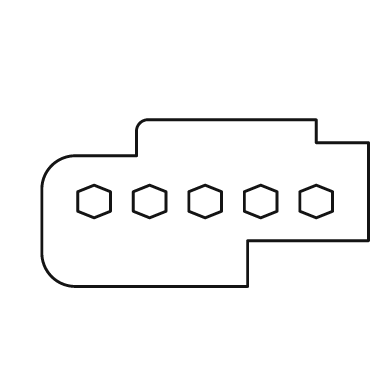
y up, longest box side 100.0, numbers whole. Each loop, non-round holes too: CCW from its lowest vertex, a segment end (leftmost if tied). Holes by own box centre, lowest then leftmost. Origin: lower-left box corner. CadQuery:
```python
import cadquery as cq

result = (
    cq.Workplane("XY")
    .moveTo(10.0, 0.0)
    .lineTo(63.0, 0.0)
    .lineTo(63.0, 14.0)
    .lineTo(100.0, 14.0)
    .lineTo(100.0, 44.0)
    .lineTo(84.0, 44.0)
    .lineTo(84.0, 51.0)
    .lineTo(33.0, 51.0)
    .threePointArc((30.0, 50.0), (29.0, 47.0))
    .lineTo(29.0, 40.0)
    .lineTo(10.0, 40.0)
    .threePointArc((3.0, 37.0), (0.0, 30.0))
    .lineTo(0.0, 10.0)
    .threePointArc((3.0, 3.0), (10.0, 0.0))
    .close()
    .moveTo(16.0, 21.0)
    .lineTo(21.0, 23.0)
    .lineTo(21.0, 29.0)
    .lineTo(16.0, 31.0)
    .lineTo(11.0, 29.0)
    .lineTo(11.0, 23.0)
    .close()
    .moveTo(33.0, 21.0)
    .lineTo(38.0, 23.0)
    .lineTo(38.0, 29.0)
    .lineTo(33.0, 31.0)
    .lineTo(28.0, 29.0)
    .lineTo(28.0, 23.0)
    .close()
    .moveTo(50.0, 21.0)
    .lineTo(55.0, 23.0)
    .lineTo(55.0, 29.0)
    .lineTo(50.0, 31.0)
    .lineTo(45.0, 29.0)
    .lineTo(45.0, 23.0)
    .close()
    .moveTo(67.0, 21.0)
    .lineTo(72.0, 23.0)
    .lineTo(72.0, 29.0)
    .lineTo(67.0, 31.0)
    .lineTo(62.0, 29.0)
    .lineTo(62.0, 23.0)
    .close()
    .moveTo(84.0, 21.0)
    .lineTo(89.0, 23.0)
    .lineTo(89.0, 29.0)
    .lineTo(84.0, 31.0)
    .lineTo(79.0, 29.0)
    .lineTo(79.0, 23.0)
    .close()
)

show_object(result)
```